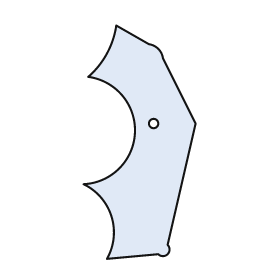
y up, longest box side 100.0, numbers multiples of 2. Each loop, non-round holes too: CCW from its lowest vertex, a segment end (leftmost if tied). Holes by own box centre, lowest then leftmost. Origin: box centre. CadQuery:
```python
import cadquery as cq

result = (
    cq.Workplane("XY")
    .moveTo(-14.0, -50.0)
    .lineTo(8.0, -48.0)
    .threePointArc((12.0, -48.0), (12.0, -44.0))
    .lineTo(24.0, 8.0)
    .lineTo(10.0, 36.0)
    .threePointArc((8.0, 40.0), (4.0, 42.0))
    .lineTo(-10.0, 50.0)
    .threePointArc((-14.0, 38.0), (-22.0, 28.0))
    .threePointArc((-2.0, 4.0), (-24.0, -18.0))
    .threePointArc((-12.0, -32.0), (-14.0, -50.0))
    .close()
    .moveTo(6.0, 8.0)
    .circle(2.0)
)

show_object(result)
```